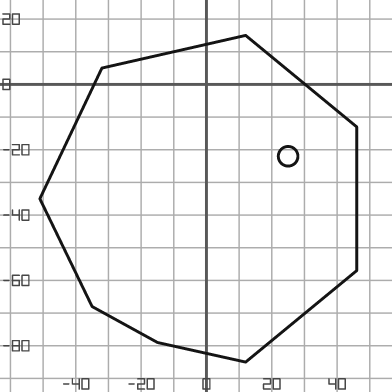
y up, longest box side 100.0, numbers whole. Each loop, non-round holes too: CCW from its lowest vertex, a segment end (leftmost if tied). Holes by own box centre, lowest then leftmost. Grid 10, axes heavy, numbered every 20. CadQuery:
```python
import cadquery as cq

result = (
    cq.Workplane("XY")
    .moveTo(12.0, -85.0)
    .lineTo(46.0, -57.0)
    .lineTo(46.0, -13.0)
    .lineTo(12.0, 15.0)
    .lineTo(-32.0, 5.0)
    .lineTo(-51.0, -35.0)
    .lineTo(-35.0, -68.0)
    .lineTo(-15.0, -79.0)
    .close()
    .moveTo(25.0, -22.0)
    .circle(3.0)
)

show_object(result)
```